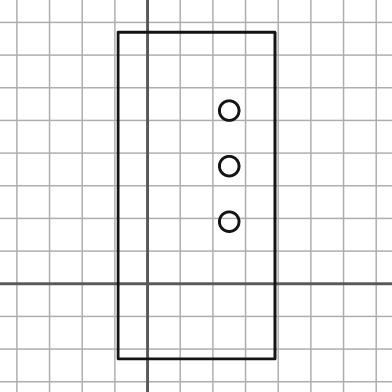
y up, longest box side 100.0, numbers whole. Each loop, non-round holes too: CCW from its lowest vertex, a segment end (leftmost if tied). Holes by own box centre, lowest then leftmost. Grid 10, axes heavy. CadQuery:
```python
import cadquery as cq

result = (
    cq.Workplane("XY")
    .moveTo(-9.0, -23.0)
    .lineTo(39.0, -23.0)
    .lineTo(39.0, 77.0)
    .lineTo(-9.0, 77.0)
    .close()
    .moveTo(25.0, 19.0)
    .circle(3.0)
    .moveTo(25.0, 36.0)
    .circle(3.0)
    .moveTo(25.0, 53.0)
    .circle(3.0)
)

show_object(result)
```